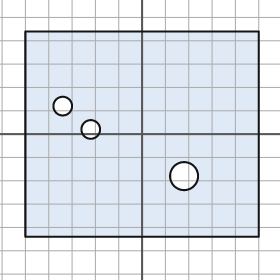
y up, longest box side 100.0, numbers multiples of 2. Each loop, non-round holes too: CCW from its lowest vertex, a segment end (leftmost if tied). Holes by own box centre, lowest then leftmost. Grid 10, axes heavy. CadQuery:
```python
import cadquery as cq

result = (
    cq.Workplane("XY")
    .moveTo(-50.0, -44.0)
    .lineTo(50.0, -44.0)
    .lineTo(50.0, 44.0)
    .lineTo(-50.0, 44.0)
    .close()
    .moveTo(18.0, -18.0)
    .circle(6.0)
    .moveTo(-22.0, 2.0)
    .circle(4.0)
    .moveTo(-34.0, 12.0)
    .circle(4.0)
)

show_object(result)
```